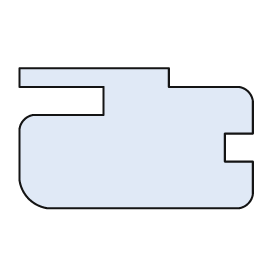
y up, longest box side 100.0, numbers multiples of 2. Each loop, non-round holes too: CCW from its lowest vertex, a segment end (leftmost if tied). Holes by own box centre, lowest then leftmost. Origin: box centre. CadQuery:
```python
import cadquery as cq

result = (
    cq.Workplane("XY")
    .moveTo(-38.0, -30.0)
    .lineTo(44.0, -30.0)
    .threePointArc((48.0, -28.0), (50.0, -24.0))
    .lineTo(50.0, -10.0)
    .lineTo(38.0, -10.0)
    .lineTo(38.0, 2.0)
    .lineTo(50.0, 2.0)
    .lineTo(50.0, 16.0)
    .threePointArc((48.0, 20.0), (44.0, 22.0))
    .lineTo(14.0, 22.0)
    .lineTo(14.0, 30.0)
    .lineTo(-50.0, 30.0)
    .lineTo(-50.0, 22.0)
    .lineTo(-14.0, 22.0)
    .lineTo(-14.0, 10.0)
    .lineTo(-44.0, 10.0)
    .threePointArc((-48.0, 8.0), (-50.0, 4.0))
    .lineTo(-50.0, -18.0)
    .threePointArc((-46.0, -26.0), (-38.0, -30.0))
    .close()
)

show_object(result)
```